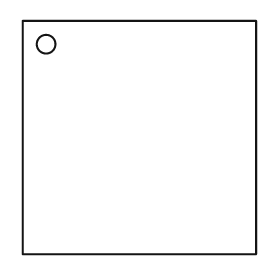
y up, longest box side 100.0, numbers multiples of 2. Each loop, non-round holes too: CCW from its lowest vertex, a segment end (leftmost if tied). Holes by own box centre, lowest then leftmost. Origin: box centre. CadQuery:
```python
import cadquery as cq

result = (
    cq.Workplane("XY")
    .moveTo(-50.0, -50.0)
    .lineTo(50.0, -50.0)
    .lineTo(50.0, 50.0)
    .lineTo(-50.0, 50.0)
    .close()
    .moveTo(-40.0, 40.0)
    .circle(4.0)
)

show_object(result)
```